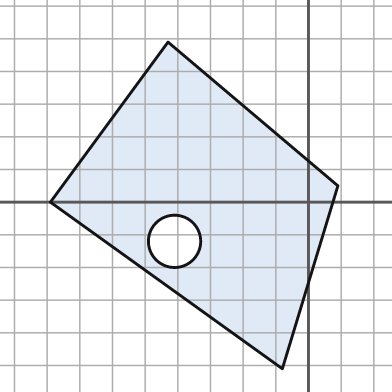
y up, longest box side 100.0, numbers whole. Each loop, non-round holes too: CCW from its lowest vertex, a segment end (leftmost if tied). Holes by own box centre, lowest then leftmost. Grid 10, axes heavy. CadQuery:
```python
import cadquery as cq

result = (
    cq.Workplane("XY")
    .moveTo(-8.0, -51.0)
    .lineTo(9.0, 5.0)
    .lineTo(-43.0, 49.0)
    .lineTo(-79.0, 0.0)
    .close()
    .moveTo(-41.0, -12.0)
    .circle(8.0)
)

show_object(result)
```